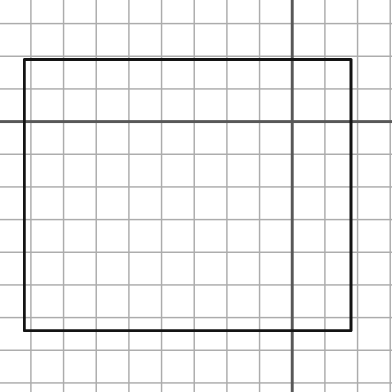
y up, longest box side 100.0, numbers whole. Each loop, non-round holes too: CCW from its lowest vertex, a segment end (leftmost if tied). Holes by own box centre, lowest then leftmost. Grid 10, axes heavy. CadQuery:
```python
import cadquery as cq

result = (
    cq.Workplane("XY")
    .moveTo(-82.0, -64.0)
    .lineTo(18.0, -64.0)
    .lineTo(18.0, 19.0)
    .lineTo(-82.0, 19.0)
    .close()
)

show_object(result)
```